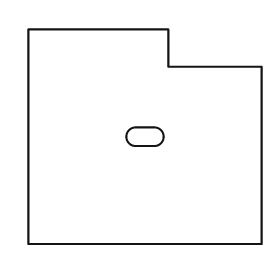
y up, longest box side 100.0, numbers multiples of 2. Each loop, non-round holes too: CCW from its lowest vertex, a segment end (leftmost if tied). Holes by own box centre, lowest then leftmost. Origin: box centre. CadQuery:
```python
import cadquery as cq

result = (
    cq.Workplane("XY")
    .moveTo(-50.0, -46.0)
    .lineTo(50.0, -46.0)
    .lineTo(50.0, 30.0)
    .lineTo(10.0, 30.0)
    .lineTo(10.0, 46.0)
    .lineTo(-50.0, 46.0)
    .close()
    .moveTo(-4.0, -4.0)
    .lineTo(4.0, -4.0)
    .threePointArc((8.0, 0.0), (4.0, 4.0))
    .lineTo(-4.0, 4.0)
    .threePointArc((-8.0, 0.0), (-4.0, -4.0))
    .close()
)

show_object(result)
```